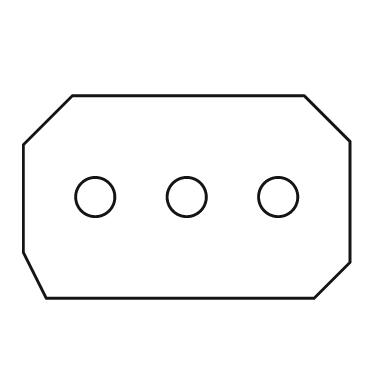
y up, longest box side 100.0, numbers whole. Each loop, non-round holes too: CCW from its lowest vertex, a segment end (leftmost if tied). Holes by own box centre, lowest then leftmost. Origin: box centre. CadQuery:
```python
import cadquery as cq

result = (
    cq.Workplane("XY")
    .moveTo(-43.0, -31.0)
    .lineTo(39.0, -31.0)
    .lineTo(50.0, -20.0)
    .lineTo(50.0, 17.0)
    .lineTo(36.0, 31.0)
    .lineTo(-35.0, 31.0)
    .lineTo(-50.0, 16.0)
    .lineTo(-50.0, -17.0)
    .close()
    .moveTo(-28.0, 0.0)
    .circle(6.0)
    .moveTo(0.0, 0.0)
    .circle(6.0)
    .moveTo(28.0, 0.0)
    .circle(6.0)
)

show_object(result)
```